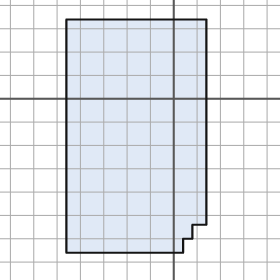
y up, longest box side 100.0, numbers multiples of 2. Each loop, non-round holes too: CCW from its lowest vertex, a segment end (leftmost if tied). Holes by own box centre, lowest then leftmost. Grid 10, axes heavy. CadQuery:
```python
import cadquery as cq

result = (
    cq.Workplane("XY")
    .moveTo(-46.0, -66.0)
    .lineTo(4.0, -66.0)
    .lineTo(4.0, -60.0)
    .lineTo(8.0, -60.0)
    .lineTo(8.0, -54.0)
    .lineTo(14.0, -54.0)
    .lineTo(14.0, 34.0)
    .lineTo(-46.0, 34.0)
    .close()
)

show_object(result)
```